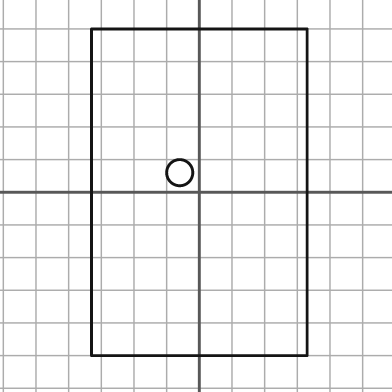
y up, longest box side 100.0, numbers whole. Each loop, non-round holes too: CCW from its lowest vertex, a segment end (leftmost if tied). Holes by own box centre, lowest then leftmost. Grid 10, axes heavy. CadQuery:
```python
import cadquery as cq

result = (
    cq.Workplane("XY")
    .moveTo(-33.0, -50.0)
    .lineTo(33.0, -50.0)
    .lineTo(33.0, 50.0)
    .lineTo(-33.0, 50.0)
    .close()
    .moveTo(-6.0, 6.0)
    .circle(4.0)
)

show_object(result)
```